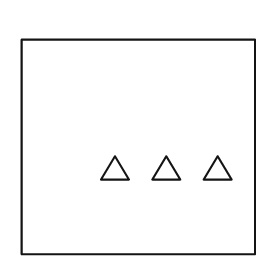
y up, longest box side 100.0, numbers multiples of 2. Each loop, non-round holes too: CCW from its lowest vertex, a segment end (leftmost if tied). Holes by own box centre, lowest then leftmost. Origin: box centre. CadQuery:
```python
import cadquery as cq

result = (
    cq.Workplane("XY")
    .moveTo(-50.0, -46.0)
    .lineTo(50.0, -46.0)
    .lineTo(50.0, 46.0)
    .lineTo(-50.0, 46.0)
    .close()
    .moveTo(-16.0, -14.0)
    .lineTo(-4.0, -14.0)
    .lineTo(-10.0, -4.0)
    .close()
    .moveTo(6.0, -14.0)
    .lineTo(18.0, -14.0)
    .lineTo(12.0, -4.0)
    .close()
    .moveTo(28.0, -14.0)
    .lineTo(40.0, -14.0)
    .lineTo(34.0, -4.0)
    .close()
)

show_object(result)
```